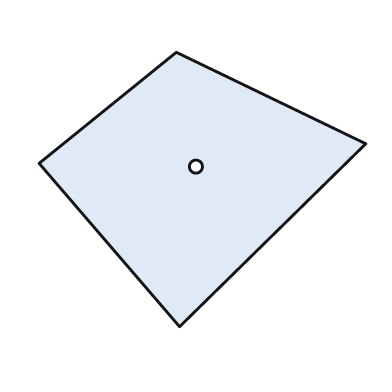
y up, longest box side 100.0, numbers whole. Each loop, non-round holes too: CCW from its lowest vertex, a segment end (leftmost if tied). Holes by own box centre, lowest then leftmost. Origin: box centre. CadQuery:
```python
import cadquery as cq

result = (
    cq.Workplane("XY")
    .moveTo(-7.0, -42.0)
    .lineTo(50.0, 14.0)
    .lineTo(-8.0, 42.0)
    .lineTo(-50.0, 8.0)
    .close()
    .moveTo(-2.0, 7.0)
    .circle(2.0)
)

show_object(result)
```